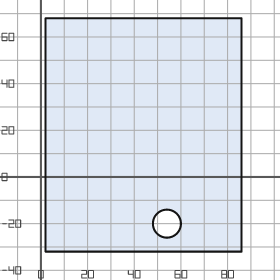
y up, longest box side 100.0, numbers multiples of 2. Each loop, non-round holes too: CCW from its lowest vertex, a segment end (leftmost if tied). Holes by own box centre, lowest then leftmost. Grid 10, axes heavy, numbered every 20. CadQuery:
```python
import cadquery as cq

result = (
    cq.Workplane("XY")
    .moveTo(2.0, -32.0)
    .lineTo(86.0, -32.0)
    .lineTo(86.0, 68.0)
    .lineTo(2.0, 68.0)
    .close()
    .moveTo(54.0, -20.0)
    .circle(6.0)
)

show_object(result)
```